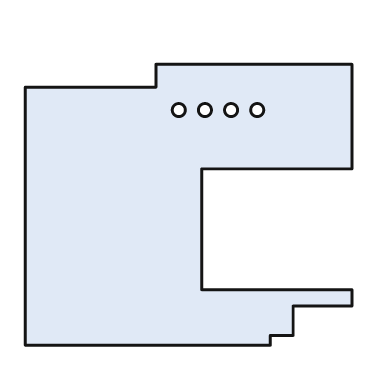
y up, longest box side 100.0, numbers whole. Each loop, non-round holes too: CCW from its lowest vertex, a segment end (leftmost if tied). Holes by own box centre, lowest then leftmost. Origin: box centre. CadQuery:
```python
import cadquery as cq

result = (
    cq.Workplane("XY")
    .moveTo(-50.0, -43.0)
    .lineTo(25.0, -43.0)
    .lineTo(25.0, -40.0)
    .lineTo(32.0, -40.0)
    .lineTo(32.0, -31.0)
    .lineTo(50.0, -31.0)
    .lineTo(50.0, -26.0)
    .lineTo(4.0, -26.0)
    .lineTo(4.0, 11.0)
    .lineTo(50.0, 11.0)
    .lineTo(50.0, 43.0)
    .lineTo(-10.0, 43.0)
    .lineTo(-10.0, 36.0)
    .lineTo(-50.0, 36.0)
    .close()
    .moveTo(-3.0, 29.0)
    .circle(2.0)
    .moveTo(5.0, 29.0)
    .circle(2.0)
    .moveTo(13.0, 29.0)
    .circle(2.0)
    .moveTo(21.0, 29.0)
    .circle(2.0)
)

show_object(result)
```